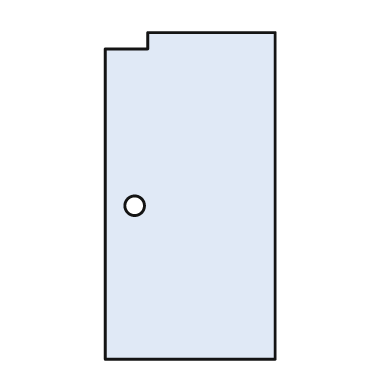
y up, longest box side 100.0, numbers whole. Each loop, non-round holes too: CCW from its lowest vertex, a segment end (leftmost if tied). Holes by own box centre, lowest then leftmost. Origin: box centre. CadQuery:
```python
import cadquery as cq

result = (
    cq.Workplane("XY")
    .moveTo(-26.0, -50.0)
    .lineTo(26.0, -50.0)
    .lineTo(26.0, 50.0)
    .lineTo(-13.0, 50.0)
    .lineTo(-13.0, 45.0)
    .lineTo(-26.0, 45.0)
    .close()
    .moveTo(-17.0, -3.0)
    .circle(3.0)
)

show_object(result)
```